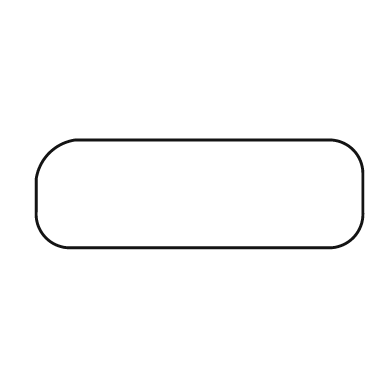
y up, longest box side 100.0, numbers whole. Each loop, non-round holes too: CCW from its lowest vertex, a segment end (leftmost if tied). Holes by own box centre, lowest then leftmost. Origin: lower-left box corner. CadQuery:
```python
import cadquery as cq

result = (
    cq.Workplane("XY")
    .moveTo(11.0, 0.0)
    .lineTo(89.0, 0.0)
    .threePointArc((97.0, 3.0), (100.0, 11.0))
    .lineTo(100.0, 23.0)
    .threePointArc((97.0, 30.0), (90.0, 33.0))
    .lineTo(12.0, 33.0)
    .threePointArc((4.0, 29.0), (0.0, 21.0))
    .lineTo(0.0, 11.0)
    .threePointArc((3.0, 3.0), (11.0, 0.0))
    .close()
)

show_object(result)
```